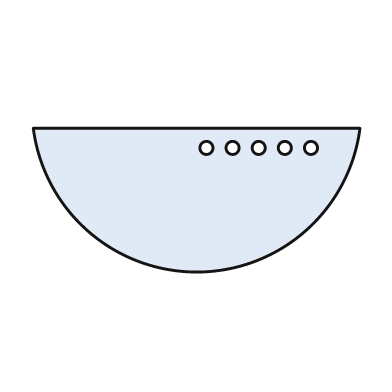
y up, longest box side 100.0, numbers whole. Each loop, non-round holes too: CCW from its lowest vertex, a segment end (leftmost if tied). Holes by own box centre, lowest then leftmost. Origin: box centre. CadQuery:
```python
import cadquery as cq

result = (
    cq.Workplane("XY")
    .moveTo(-50.0, 22.0)
    .threePointArc((0.0, -22.0), (50.0, 22.0))
    .close()
    .moveTo(3.0, 16.0)
    .circle(2.0)
    .moveTo(11.0, 16.0)
    .circle(2.0)
    .moveTo(19.0, 16.0)
    .circle(2.0)
    .moveTo(27.0, 16.0)
    .circle(2.0)
    .moveTo(35.0, 16.0)
    .circle(2.0)
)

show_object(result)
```